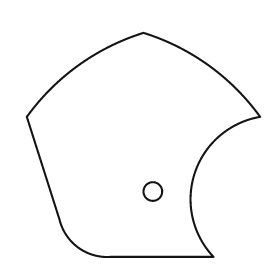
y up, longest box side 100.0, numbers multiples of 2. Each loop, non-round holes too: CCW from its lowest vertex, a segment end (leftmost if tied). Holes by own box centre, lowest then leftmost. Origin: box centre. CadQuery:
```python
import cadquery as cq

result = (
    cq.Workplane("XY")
    .moveTo(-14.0, -48.0)
    .lineTo(30.0, -48.0)
    .threePointArc((22.0, -12.0), (50.0, 12.0))
    .threePointArc((28.0, 34.0), (0.0, 48.0))
    .threePointArc((-28.0, 34.0), (-50.0, 12.0))
    .lineTo(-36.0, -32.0)
    .threePointArc((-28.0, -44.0), (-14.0, -48.0))
    .close()
    .moveTo(4.0, -20.0)
    .circle(4.0)
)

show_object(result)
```